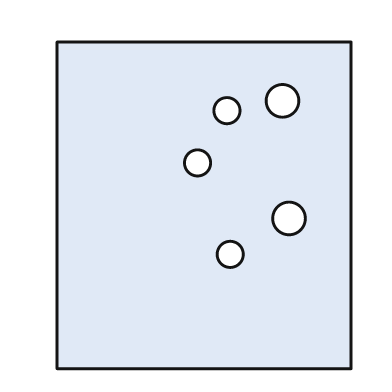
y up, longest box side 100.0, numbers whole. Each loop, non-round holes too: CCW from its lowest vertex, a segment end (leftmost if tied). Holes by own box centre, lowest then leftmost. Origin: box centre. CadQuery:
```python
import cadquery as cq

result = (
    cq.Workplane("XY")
    .moveTo(-45.0, -50.0)
    .lineTo(45.0, -50.0)
    .lineTo(45.0, 50.0)
    .lineTo(-45.0, 50.0)
    .close()
    .moveTo(8.0, -15.0)
    .circle(4.0)
    .moveTo(26.0, -4.0)
    .circle(5.0)
    .moveTo(-2.0, 13.0)
    .circle(4.0)
    .moveTo(7.0, 29.0)
    .circle(4.0)
    .moveTo(24.0, 32.0)
    .circle(5.0)
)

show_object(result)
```